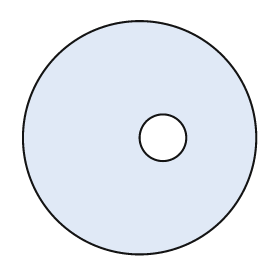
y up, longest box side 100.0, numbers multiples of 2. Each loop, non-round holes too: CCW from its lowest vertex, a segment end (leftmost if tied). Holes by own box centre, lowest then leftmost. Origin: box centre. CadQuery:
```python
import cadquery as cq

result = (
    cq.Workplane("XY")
    .moveTo(0.0, 0.0)
    .circle(50.0)
    .moveTo(10.0, 0.0)
    .circle(10.0)
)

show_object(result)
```